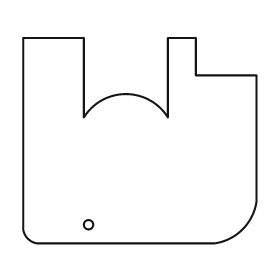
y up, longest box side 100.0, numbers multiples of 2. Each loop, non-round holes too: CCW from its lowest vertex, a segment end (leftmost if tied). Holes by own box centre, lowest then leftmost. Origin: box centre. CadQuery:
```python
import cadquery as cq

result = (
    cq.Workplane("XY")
    .moveTo(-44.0, -44.0)
    .lineTo(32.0, -44.0)
    .threePointArc((44.0, -38.0), (50.0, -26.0))
    .lineTo(50.0, 28.0)
    .lineTo(24.0, 28.0)
    .lineTo(24.0, 44.0)
    .lineTo(12.0, 44.0)
    .lineTo(12.0, 10.0)
    .threePointArc((-6.0, 20.0), (-24.0, 10.0))
    .lineTo(-24.0, 44.0)
    .lineTo(-50.0, 44.0)
    .lineTo(-50.0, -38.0)
    .threePointArc((-48.0, -42.0), (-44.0, -44.0))
    .close()
    .moveTo(-22.0, -36.0)
    .circle(2.0)
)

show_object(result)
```